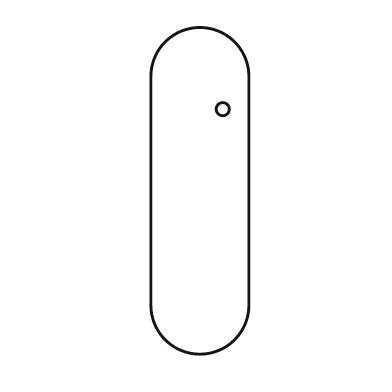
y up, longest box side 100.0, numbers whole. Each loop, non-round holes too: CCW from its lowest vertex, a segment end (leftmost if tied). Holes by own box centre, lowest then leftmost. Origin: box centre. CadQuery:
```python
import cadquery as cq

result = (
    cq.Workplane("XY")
    .moveTo(-15.0, -35.0)
    .threePointArc((0.0, -50.0), (15.0, -35.0))
    .lineTo(15.0, 35.0)
    .threePointArc((0.0, 50.0), (-15.0, 35.0))
    .close()
    .moveTo(7.0, 25.0)
    .circle(2.0)
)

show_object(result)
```